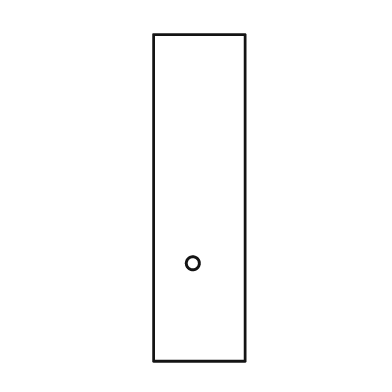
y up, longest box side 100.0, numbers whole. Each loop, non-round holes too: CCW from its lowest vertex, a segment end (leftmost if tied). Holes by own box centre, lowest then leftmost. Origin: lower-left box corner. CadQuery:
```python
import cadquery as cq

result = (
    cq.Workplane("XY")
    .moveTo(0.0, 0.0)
    .lineTo(28.0, 0.0)
    .lineTo(28.0, 100.0)
    .lineTo(0.0, 100.0)
    .close()
    .moveTo(12.0, 30.0)
    .circle(2.0)
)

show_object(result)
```